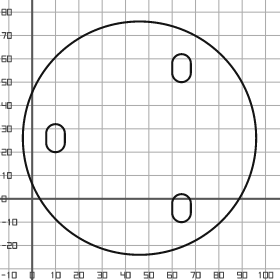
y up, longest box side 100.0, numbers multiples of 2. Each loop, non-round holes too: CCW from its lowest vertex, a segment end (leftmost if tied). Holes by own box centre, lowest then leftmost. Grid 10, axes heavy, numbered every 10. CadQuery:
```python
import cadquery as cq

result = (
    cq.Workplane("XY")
    .moveTo(46.0, 26.0)
    .circle(50.0)
    .moveTo(60.0, -6.0)
    .threePointArc((64.0, -10.0), (68.0, -6.0))
    .lineTo(68.0, -2.0)
    .threePointArc((64.0, 2.0), (60.0, -2.0))
    .close()
    .moveTo(6.0, 24.0)
    .threePointArc((10.0, 20.0), (14.0, 24.0))
    .lineTo(14.0, 28.0)
    .threePointArc((10.0, 32.0), (6.0, 28.0))
    .close()
    .moveTo(60.0, 54.0)
    .threePointArc((64.0, 50.0), (68.0, 54.0))
    .lineTo(68.0, 58.0)
    .threePointArc((64.0, 62.0), (60.0, 58.0))
    .close()
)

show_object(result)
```